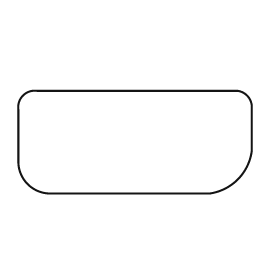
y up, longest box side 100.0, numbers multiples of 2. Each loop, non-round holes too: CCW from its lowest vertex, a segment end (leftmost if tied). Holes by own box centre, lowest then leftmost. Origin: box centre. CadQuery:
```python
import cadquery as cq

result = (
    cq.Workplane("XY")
    .moveTo(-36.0, -22.0)
    .lineTo(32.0, -22.0)
    .threePointArc((44.0, -16.0), (50.0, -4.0))
    .lineTo(50.0, 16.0)
    .threePointArc((48.0, 20.0), (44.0, 22.0))
    .lineTo(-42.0, 22.0)
    .threePointArc((-48.0, 20.0), (-50.0, 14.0))
    .lineTo(-50.0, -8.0)
    .threePointArc((-46.0, -18.0), (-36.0, -22.0))
    .close()
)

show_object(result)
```